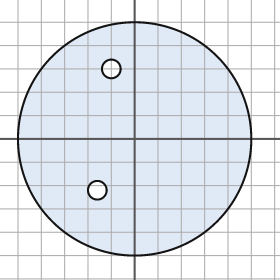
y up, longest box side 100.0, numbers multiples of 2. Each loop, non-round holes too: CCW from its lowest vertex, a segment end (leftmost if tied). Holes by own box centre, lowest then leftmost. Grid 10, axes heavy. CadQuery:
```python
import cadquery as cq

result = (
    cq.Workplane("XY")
    .moveTo(0.0, 0.0)
    .circle(50.0)
    .moveTo(-16.0, -22.0)
    .circle(4.0)
    .moveTo(-10.0, 30.0)
    .circle(4.0)
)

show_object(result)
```